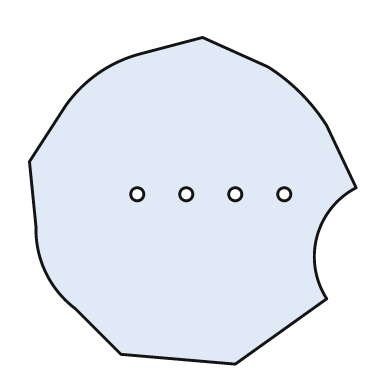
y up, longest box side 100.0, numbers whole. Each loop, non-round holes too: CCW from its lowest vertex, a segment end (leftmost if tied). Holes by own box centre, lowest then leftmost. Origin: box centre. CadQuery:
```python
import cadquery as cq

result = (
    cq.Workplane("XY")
    .moveTo(13.0, -50.0)
    .lineTo(41.0, -30.0)
    .threePointArc((38.0, -11.0), (50.0, 4.0))
    .lineTo(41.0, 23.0)
    .threePointArc((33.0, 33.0), (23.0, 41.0))
    .lineTo(3.0, 50.0)
    .lineTo(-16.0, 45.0)
    .threePointArc((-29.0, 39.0), (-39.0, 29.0))
    .lineTo(-50.0, 12.0)
    .lineTo(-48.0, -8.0)
    .threePointArc((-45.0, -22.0), (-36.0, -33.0))
    .lineTo(-22.0, -47.0)
    .close()
    .moveTo(-17.0, 2.0)
    .circle(2.0)
    .moveTo(-2.0, 2.0)
    .circle(2.0)
    .moveTo(13.0, 2.0)
    .circle(2.0)
    .moveTo(28.0, 2.0)
    .circle(2.0)
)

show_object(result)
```